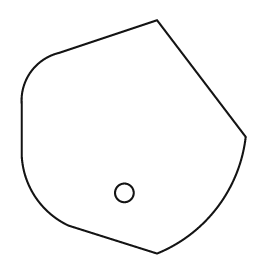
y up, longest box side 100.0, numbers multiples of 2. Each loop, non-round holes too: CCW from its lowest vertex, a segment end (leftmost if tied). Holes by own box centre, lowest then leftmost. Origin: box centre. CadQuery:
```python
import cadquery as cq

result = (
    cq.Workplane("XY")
    .moveTo(10.0, -50.0)
    .threePointArc((36.0, -30.0), (48.0, 0.0))
    .lineTo(10.0, 50.0)
    .lineTo(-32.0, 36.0)
    .threePointArc((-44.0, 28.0), (-48.0, 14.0))
    .lineTo(-48.0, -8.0)
    .threePointArc((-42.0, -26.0), (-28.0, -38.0))
    .close()
    .moveTo(-4.0, -24.0)
    .circle(4.0)
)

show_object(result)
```